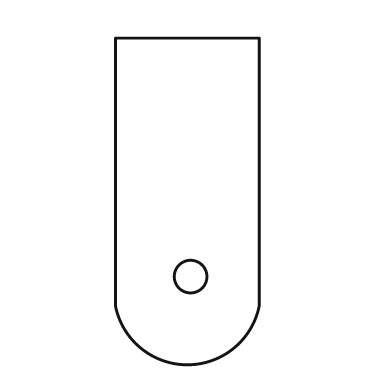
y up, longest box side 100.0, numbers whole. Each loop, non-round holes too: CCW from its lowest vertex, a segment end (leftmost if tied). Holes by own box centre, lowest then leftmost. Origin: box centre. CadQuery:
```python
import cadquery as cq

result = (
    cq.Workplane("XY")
    .moveTo(-22.0, -32.0)
    .threePointArc((0.0, -50.0), (22.0, -32.0))
    .lineTo(22.0, 50.0)
    .lineTo(-22.0, 50.0)
    .close()
    .moveTo(1.0, -23.0)
    .circle(5.0)
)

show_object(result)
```